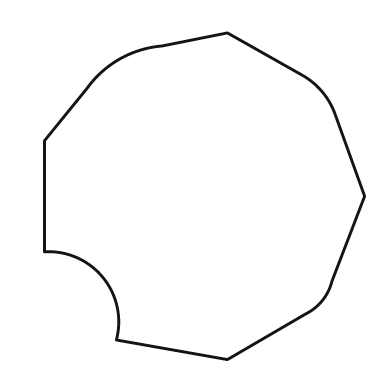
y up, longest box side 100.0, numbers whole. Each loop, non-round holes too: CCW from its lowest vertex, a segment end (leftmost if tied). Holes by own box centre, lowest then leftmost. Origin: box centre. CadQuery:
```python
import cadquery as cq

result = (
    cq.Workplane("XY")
    .moveTo(7.0, -50.0)
    .lineTo(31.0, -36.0)
    .threePointArc((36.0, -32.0), (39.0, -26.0))
    .lineTo(49.0, 0.0)
    .lineTo(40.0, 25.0)
    .threePointArc((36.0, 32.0), (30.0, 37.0))
    .lineTo(7.0, 50.0)
    .lineTo(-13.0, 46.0)
    .threePointArc((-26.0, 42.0), (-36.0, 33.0))
    .lineTo(-49.0, 17.0)
    .lineTo(-49.0, -17.0)
    .threePointArc((-31.0, -25.0), (-27.0, -44.0))
    .close()
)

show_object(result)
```